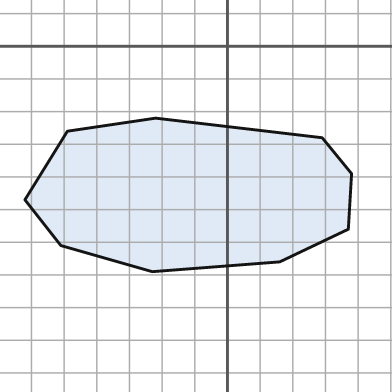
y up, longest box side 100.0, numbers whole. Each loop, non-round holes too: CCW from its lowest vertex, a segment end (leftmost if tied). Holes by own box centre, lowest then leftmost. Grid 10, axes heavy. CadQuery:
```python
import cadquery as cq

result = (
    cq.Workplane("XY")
    .moveTo(-23.0, -69.0)
    .lineTo(16.0, -66.0)
    .lineTo(37.0, -56.0)
    .lineTo(38.0, -39.0)
    .lineTo(29.0, -28.0)
    .lineTo(-22.0, -22.0)
    .lineTo(-49.0, -26.0)
    .lineTo(-62.0, -47.0)
    .lineTo(-51.0, -61.0)
    .close()
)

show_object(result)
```